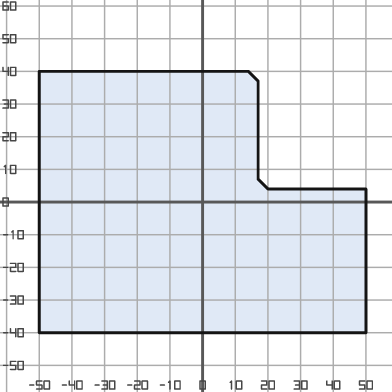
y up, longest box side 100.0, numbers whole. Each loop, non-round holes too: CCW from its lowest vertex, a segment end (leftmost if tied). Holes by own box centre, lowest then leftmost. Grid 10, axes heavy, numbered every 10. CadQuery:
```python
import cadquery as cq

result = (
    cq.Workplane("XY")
    .moveTo(-50.0, -40.0)
    .lineTo(50.0, -40.0)
    .lineTo(50.0, 4.0)
    .lineTo(20.0, 4.0)
    .lineTo(17.0, 7.0)
    .lineTo(17.0, 37.0)
    .lineTo(14.0, 40.0)
    .lineTo(-50.0, 40.0)
    .close()
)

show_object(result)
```